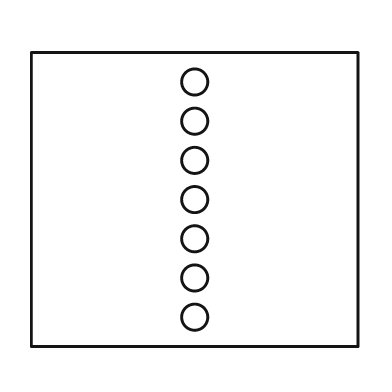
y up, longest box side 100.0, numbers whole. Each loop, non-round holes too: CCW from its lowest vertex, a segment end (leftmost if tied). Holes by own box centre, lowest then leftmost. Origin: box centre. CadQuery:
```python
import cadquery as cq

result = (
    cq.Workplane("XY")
    .moveTo(-50.0, -45.0)
    .lineTo(50.0, -45.0)
    .lineTo(50.0, 45.0)
    .lineTo(-50.0, 45.0)
    .close()
    .moveTo(0.0, -36.0)
    .circle(4.0)
    .moveTo(0.0, -24.0)
    .circle(4.0)
    .moveTo(0.0, -12.0)
    .circle(4.0)
    .moveTo(0.0, 0.0)
    .circle(4.0)
    .moveTo(0.0, 12.0)
    .circle(4.0)
    .moveTo(0.0, 24.0)
    .circle(4.0)
    .moveTo(0.0, 36.0)
    .circle(4.0)
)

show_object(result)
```